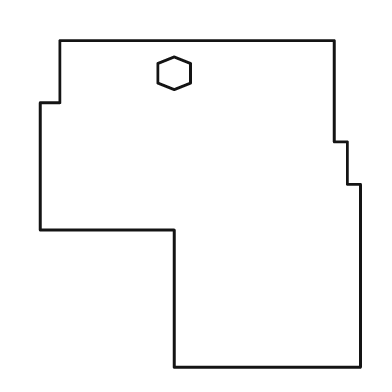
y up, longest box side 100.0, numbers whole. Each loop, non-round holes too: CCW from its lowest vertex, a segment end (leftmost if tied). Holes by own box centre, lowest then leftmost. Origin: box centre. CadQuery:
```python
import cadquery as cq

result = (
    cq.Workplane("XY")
    .moveTo(-8.0, -50.0)
    .lineTo(49.0, -50.0)
    .lineTo(49.0, 6.0)
    .lineTo(45.0, 6.0)
    .lineTo(45.0, 19.0)
    .lineTo(41.0, 19.0)
    .lineTo(41.0, 50.0)
    .lineTo(-43.0, 50.0)
    .lineTo(-43.0, 31.0)
    .lineTo(-49.0, 31.0)
    .lineTo(-49.0, -8.0)
    .lineTo(-8.0, -8.0)
    .close()
    .moveTo(-8.0, 35.0)
    .lineTo(-3.0, 37.0)
    .lineTo(-3.0, 43.0)
    .lineTo(-8.0, 45.0)
    .lineTo(-13.0, 43.0)
    .lineTo(-13.0, 37.0)
    .close()
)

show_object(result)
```